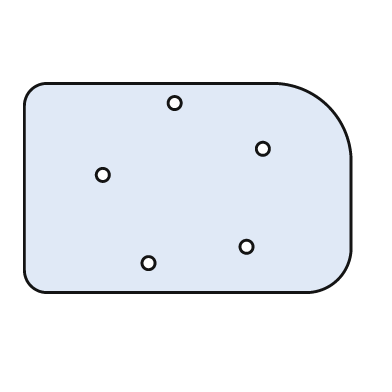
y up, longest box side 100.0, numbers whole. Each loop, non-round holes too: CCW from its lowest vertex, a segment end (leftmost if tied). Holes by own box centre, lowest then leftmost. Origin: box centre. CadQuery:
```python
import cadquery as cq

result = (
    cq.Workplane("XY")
    .moveTo(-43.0, -32.0)
    .lineTo(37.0, -32.0)
    .threePointArc((46.0, -28.0), (50.0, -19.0))
    .lineTo(50.0, 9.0)
    .threePointArc((43.0, 25.0), (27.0, 32.0))
    .lineTo(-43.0, 32.0)
    .threePointArc((-48.0, 30.0), (-50.0, 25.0))
    .lineTo(-50.0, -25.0)
    .threePointArc((-48.0, -30.0), (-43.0, -32.0))
    .close()
    .moveTo(-12.0, -23.0)
    .circle(2.0)
    .moveTo(18.0, -18.0)
    .circle(2.0)
    .moveTo(-26.0, 4.0)
    .circle(2.0)
    .moveTo(23.0, 12.0)
    .circle(2.0)
    .moveTo(-4.0, 26.0)
    .circle(2.0)
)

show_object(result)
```